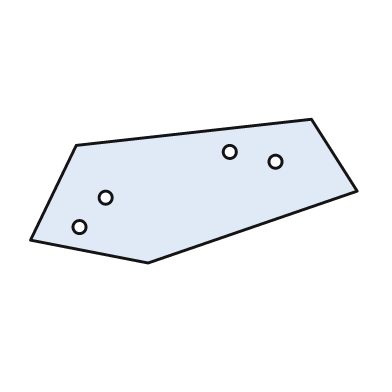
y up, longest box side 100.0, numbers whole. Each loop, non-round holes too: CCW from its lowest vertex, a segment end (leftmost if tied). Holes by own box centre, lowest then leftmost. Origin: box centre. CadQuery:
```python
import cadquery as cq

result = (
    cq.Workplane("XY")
    .moveTo(-14.0, -22.0)
    .lineTo(50.0, 0.0)
    .lineTo(36.0, 22.0)
    .lineTo(-36.0, 14.0)
    .lineTo(-50.0, -15.0)
    .close()
    .moveTo(-35.0, -11.0)
    .circle(2.0)
    .moveTo(-27.0, -2.0)
    .circle(2.0)
    .moveTo(25.0, 9.0)
    .circle(2.0)
    .moveTo(11.0, 12.0)
    .circle(2.0)
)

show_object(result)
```